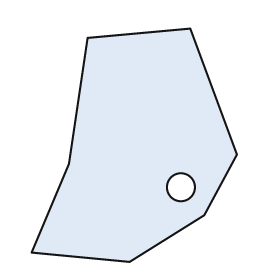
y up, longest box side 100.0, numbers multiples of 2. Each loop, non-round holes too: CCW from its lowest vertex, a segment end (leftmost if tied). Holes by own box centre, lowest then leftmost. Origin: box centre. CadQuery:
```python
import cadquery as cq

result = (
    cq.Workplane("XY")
    .moveTo(-2.0, -50.0)
    .lineTo(30.0, -30.0)
    .lineTo(44.0, -4.0)
    .lineTo(24.0, 50.0)
    .lineTo(-20.0, 46.0)
    .lineTo(-28.0, -8.0)
    .lineTo(-44.0, -46.0)
    .close()
    .moveTo(20.0, -18.0)
    .circle(6.0)
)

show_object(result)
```